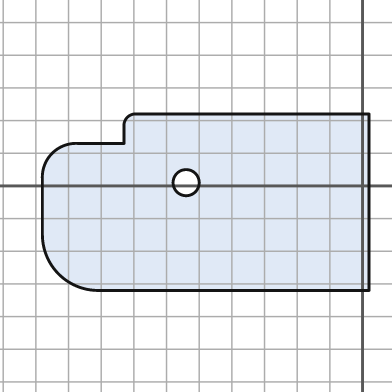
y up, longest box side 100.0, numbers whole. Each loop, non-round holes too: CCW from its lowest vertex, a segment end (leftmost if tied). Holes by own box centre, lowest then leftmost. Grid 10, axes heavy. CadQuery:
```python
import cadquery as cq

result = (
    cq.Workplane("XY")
    .moveTo(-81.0, -32.0)
    .lineTo(2.0, -32.0)
    .lineTo(2.0, 22.0)
    .lineTo(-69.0, 22.0)
    .threePointArc((-72.0, 21.0), (-73.0, 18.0))
    .lineTo(-73.0, 13.0)
    .lineTo(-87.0, 13.0)
    .threePointArc((-95.0, 10.0), (-98.0, 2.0))
    .lineTo(-98.0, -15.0)
    .threePointArc((-93.0, -27.0), (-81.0, -32.0))
    .close()
    .moveTo(-54.0, 1.0)
    .circle(4.0)
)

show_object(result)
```